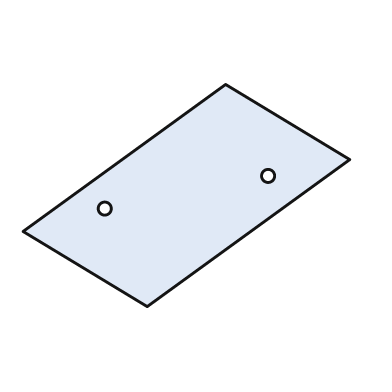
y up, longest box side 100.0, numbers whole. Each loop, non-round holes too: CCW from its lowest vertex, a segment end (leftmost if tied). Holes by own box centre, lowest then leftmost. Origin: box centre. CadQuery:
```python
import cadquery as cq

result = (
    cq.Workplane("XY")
    .moveTo(-12.0, -34.0)
    .lineTo(50.0, 11.0)
    .lineTo(12.0, 34.0)
    .lineTo(-50.0, -11.0)
    .close()
    .moveTo(-25.0, -4.0)
    .circle(2.0)
    .moveTo(25.0, 6.0)
    .circle(2.0)
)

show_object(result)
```